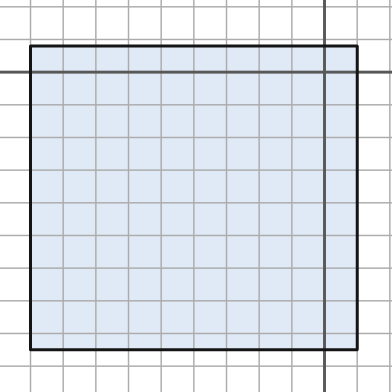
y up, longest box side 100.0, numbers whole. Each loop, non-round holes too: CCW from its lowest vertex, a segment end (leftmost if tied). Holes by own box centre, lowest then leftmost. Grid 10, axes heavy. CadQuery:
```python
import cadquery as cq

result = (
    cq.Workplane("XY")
    .moveTo(-90.0, -85.0)
    .lineTo(10.0, -85.0)
    .lineTo(10.0, 8.0)
    .lineTo(-90.0, 8.0)
    .close()
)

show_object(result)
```